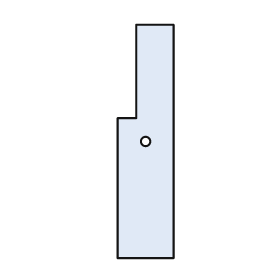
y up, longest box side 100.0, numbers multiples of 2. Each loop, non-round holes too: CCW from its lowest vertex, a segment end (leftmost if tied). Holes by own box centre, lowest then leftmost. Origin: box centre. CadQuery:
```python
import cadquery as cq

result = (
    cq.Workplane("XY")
    .moveTo(-12.0, -50.0)
    .lineTo(12.0, -50.0)
    .lineTo(12.0, 50.0)
    .lineTo(-4.0, 50.0)
    .lineTo(-4.0, 10.0)
    .lineTo(-12.0, 10.0)
    .close()
    .moveTo(0.0, 0.0)
    .circle(2.0)
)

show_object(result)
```